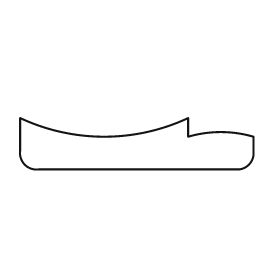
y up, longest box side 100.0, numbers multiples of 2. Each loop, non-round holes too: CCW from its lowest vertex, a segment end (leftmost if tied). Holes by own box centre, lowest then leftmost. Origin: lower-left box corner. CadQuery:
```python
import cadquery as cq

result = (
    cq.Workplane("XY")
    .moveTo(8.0, 0.0)
    .lineTo(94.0, 0.0)
    .threePointArc((98.0, 2.0), (100.0, 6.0))
    .lineTo(100.0, 14.0)
    .threePointArc((86.0, 16.0), (72.0, 14.0))
    .lineTo(72.0, 22.0)
    .threePointArc((36.0, 14.0), (0.0, 22.0))
    .lineTo(0.0, 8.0)
    .threePointArc((2.0, 2.0), (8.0, 0.0))
    .close()
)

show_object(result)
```